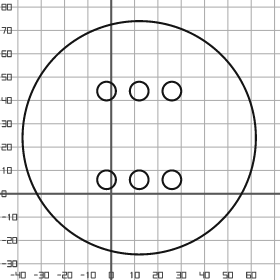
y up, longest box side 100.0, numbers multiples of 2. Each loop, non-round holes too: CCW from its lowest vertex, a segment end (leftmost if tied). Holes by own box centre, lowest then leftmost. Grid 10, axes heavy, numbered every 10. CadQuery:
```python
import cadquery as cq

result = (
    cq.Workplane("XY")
    .moveTo(12.0, 24.0)
    .circle(50.0)
    .moveTo(-2.0, 6.0)
    .circle(4.0)
    .moveTo(12.0, 6.0)
    .circle(4.0)
    .moveTo(26.0, 6.0)
    .circle(4.0)
    .moveTo(-2.0, 44.0)
    .circle(4.0)
    .moveTo(12.0, 44.0)
    .circle(4.0)
    .moveTo(26.0, 44.0)
    .circle(4.0)
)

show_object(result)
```